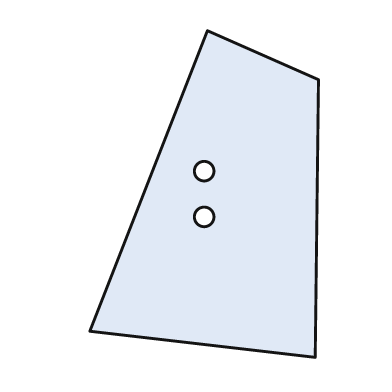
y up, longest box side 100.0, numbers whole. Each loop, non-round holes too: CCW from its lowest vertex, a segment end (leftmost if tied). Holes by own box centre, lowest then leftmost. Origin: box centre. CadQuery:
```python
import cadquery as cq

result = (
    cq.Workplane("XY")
    .moveTo(34.0, -50.0)
    .lineTo(35.0, 35.0)
    .lineTo(1.0, 50.0)
    .lineTo(-35.0, -42.0)
    .close()
    .moveTo(0.0, -7.0)
    .circle(3.0)
    .moveTo(0.0, 7.0)
    .circle(3.0)
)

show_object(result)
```